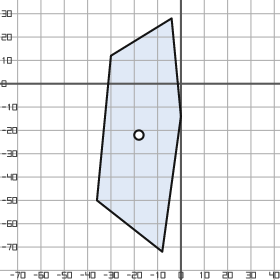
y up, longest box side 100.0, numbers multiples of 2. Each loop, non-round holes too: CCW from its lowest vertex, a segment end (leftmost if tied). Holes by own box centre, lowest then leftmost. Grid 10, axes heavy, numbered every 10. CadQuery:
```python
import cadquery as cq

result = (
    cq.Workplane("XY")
    .moveTo(-8.0, -72.0)
    .lineTo(0.0, -14.0)
    .lineTo(-4.0, 28.0)
    .lineTo(-30.0, 12.0)
    .lineTo(-36.0, -50.0)
    .close()
    .moveTo(-18.0, -22.0)
    .circle(2.0)
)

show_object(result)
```